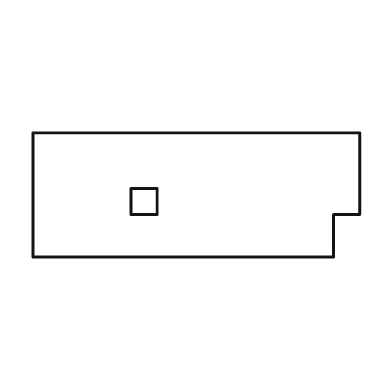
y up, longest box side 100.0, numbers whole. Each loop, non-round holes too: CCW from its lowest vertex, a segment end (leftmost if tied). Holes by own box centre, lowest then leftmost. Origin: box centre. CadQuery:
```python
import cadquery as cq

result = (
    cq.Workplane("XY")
    .moveTo(-50.0, -19.0)
    .lineTo(42.0, -19.0)
    .lineTo(42.0, -6.0)
    .lineTo(50.0, -6.0)
    .lineTo(50.0, 19.0)
    .lineTo(-50.0, 19.0)
    .close()
    .moveTo(-20.0, -6.0)
    .lineTo(-12.0, -6.0)
    .lineTo(-12.0, 2.0)
    .lineTo(-20.0, 2.0)
    .close()
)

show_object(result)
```